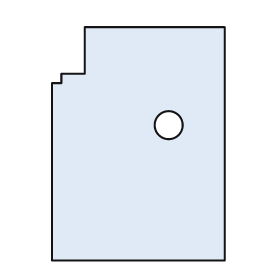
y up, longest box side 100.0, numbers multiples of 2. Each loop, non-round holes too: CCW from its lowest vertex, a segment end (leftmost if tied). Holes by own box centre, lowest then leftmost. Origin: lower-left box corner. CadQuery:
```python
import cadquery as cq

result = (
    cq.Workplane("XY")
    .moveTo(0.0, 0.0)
    .lineTo(74.0, 0.0)
    .lineTo(74.0, 100.0)
    .lineTo(14.0, 100.0)
    .lineTo(14.0, 80.0)
    .lineTo(4.0, 80.0)
    .lineTo(4.0, 76.0)
    .lineTo(0.0, 76.0)
    .close()
    .moveTo(50.0, 58.0)
    .circle(6.0)
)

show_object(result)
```